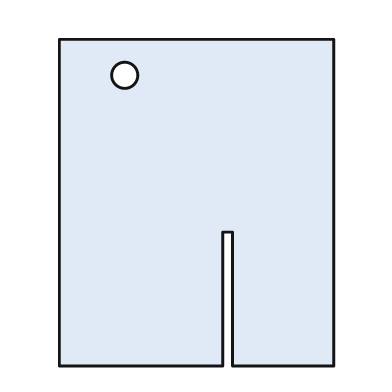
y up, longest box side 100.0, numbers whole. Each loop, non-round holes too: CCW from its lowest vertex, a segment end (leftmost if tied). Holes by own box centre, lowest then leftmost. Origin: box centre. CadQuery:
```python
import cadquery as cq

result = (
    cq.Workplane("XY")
    .moveTo(-42.0, -50.0)
    .lineTo(8.0, -50.0)
    .lineTo(8.0, -9.0)
    .lineTo(11.0, -9.0)
    .lineTo(11.0, -50.0)
    .lineTo(42.0, -50.0)
    .lineTo(42.0, 50.0)
    .lineTo(-42.0, 50.0)
    .close()
    .moveTo(-22.0, 39.0)
    .circle(4.0)
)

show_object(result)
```